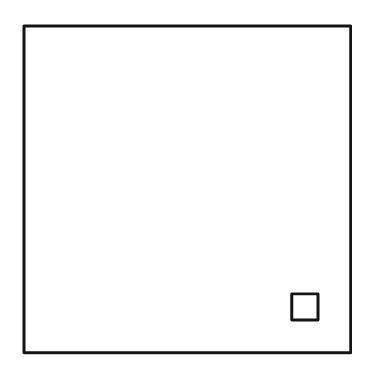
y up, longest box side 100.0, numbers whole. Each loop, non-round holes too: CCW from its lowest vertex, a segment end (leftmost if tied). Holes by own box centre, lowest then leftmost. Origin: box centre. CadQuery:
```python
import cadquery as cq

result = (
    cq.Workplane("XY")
    .moveTo(-50.0, -50.0)
    .lineTo(50.0, -50.0)
    .lineTo(50.0, 50.0)
    .lineTo(-50.0, 50.0)
    .close()
    .moveTo(32.0, -40.0)
    .lineTo(40.0, -40.0)
    .lineTo(40.0, -32.0)
    .lineTo(32.0, -32.0)
    .close()
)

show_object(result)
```